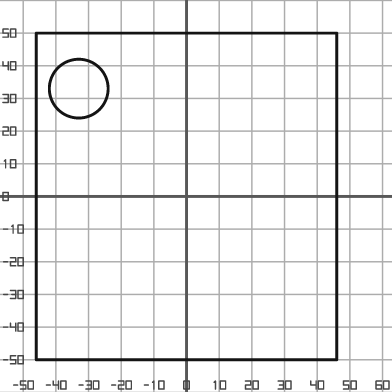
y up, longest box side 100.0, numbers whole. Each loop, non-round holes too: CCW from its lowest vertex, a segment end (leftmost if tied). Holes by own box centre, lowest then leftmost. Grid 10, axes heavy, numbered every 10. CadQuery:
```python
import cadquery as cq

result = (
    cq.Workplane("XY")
    .moveTo(-46.0, -50.0)
    .lineTo(46.0, -50.0)
    .lineTo(46.0, 50.0)
    .lineTo(-46.0, 50.0)
    .close()
    .moveTo(-33.0, 33.0)
    .circle(9.0)
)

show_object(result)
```